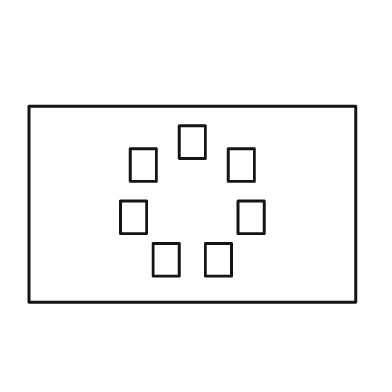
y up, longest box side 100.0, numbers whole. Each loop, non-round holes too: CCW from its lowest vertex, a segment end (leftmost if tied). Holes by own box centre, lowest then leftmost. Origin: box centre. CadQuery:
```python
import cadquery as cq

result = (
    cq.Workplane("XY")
    .moveTo(-50.0, -30.0)
    .lineTo(50.0, -30.0)
    .lineTo(50.0, 30.0)
    .lineTo(-50.0, 30.0)
    .close()
    .moveTo(-12.0, -22.0)
    .lineTo(-4.0, -22.0)
    .lineTo(-4.0, -12.0)
    .lineTo(-12.0, -12.0)
    .close()
    .moveTo(4.0, -22.0)
    .lineTo(12.0, -22.0)
    .lineTo(12.0, -12.0)
    .lineTo(4.0, -12.0)
    .close()
    .moveTo(-22.0, -9.0)
    .lineTo(-14.0, -9.0)
    .lineTo(-14.0, 1.0)
    .lineTo(-22.0, 1.0)
    .close()
    .moveTo(14.0, -9.0)
    .lineTo(22.0, -9.0)
    .lineTo(22.0, 1.0)
    .lineTo(14.0, 1.0)
    .close()
    .moveTo(-19.0, 7.0)
    .lineTo(-11.0, 7.0)
    .lineTo(-11.0, 17.0)
    .lineTo(-19.0, 17.0)
    .close()
    .moveTo(11.0, 7.0)
    .lineTo(19.0, 7.0)
    .lineTo(19.0, 17.0)
    .lineTo(11.0, 17.0)
    .close()
    .moveTo(-4.0, 14.0)
    .lineTo(4.0, 14.0)
    .lineTo(4.0, 24.0)
    .lineTo(-4.0, 24.0)
    .close()
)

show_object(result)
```